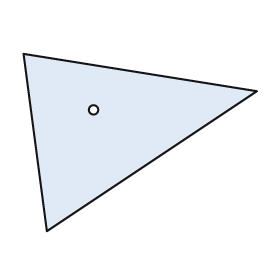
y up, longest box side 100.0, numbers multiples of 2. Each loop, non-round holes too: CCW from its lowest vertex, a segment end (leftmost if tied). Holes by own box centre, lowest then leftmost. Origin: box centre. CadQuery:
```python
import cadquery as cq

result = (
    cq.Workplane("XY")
    .moveTo(-40.0, -38.0)
    .lineTo(50.0, 22.0)
    .lineTo(-50.0, 38.0)
    .close()
    .moveTo(-20.0, 14.0)
    .circle(2.0)
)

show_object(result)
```